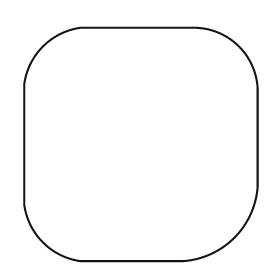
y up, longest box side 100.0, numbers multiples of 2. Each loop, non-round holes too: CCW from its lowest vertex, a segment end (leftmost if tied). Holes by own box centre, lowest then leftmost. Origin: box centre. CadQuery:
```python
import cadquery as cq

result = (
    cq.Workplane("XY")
    .moveTo(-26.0, -50.0)
    .lineTo(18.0, -50.0)
    .threePointArc((40.0, -40.0), (50.0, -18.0))
    .lineTo(50.0, 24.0)
    .threePointArc((42.0, 42.0), (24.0, 50.0))
    .lineTo(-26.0, 50.0)
    .threePointArc((-42.0, 42.0), (-50.0, 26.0))
    .lineTo(-50.0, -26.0)
    .threePointArc((-42.0, -42.0), (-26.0, -50.0))
    .close()
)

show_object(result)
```